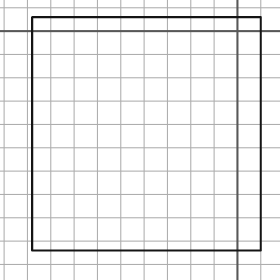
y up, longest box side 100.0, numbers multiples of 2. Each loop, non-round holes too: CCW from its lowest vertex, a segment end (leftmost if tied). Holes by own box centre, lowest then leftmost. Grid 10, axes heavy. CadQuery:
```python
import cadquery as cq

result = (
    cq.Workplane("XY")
    .moveTo(-88.0, -94.0)
    .lineTo(10.0, -94.0)
    .lineTo(10.0, 6.0)
    .lineTo(-88.0, 6.0)
    .close()
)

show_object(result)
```